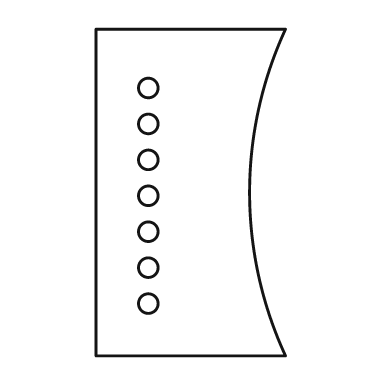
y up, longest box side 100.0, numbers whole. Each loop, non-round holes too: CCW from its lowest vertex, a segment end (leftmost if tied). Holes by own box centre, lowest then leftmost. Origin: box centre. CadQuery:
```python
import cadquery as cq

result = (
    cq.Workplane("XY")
    .moveTo(-29.0, -50.0)
    .lineTo(29.0, -50.0)
    .threePointArc((18.0, 0.0), (29.0, 50.0))
    .lineTo(-29.0, 50.0)
    .close()
    .moveTo(-13.0, -34.0)
    .circle(3.0)
    .moveTo(-13.0, -23.0)
    .circle(3.0)
    .moveTo(-13.0, -12.0)
    .circle(3.0)
    .moveTo(-13.0, -1.0)
    .circle(3.0)
    .moveTo(-13.0, 10.0)
    .circle(3.0)
    .moveTo(-13.0, 21.0)
    .circle(3.0)
    .moveTo(-13.0, 32.0)
    .circle(3.0)
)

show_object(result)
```